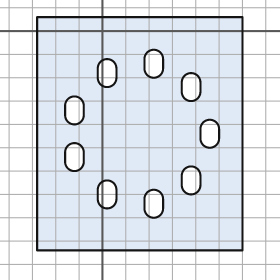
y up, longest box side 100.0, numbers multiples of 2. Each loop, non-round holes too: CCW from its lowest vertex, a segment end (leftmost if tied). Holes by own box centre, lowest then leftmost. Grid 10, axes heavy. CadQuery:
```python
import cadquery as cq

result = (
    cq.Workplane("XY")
    .moveTo(-28.0, -94.0)
    .lineTo(60.0, -94.0)
    .lineTo(60.0, 6.0)
    .lineTo(-28.0, 6.0)
    .close()
    .moveTo(18.0, -76.0)
    .threePointArc((22.0, -80.0), (26.0, -76.0))
    .lineTo(26.0, -72.0)
    .threePointArc((22.0, -68.0), (18.0, -72.0))
    .close()
    .moveTo(-2.0, -72.0)
    .threePointArc((2.0, -76.0), (6.0, -72.0))
    .lineTo(6.0, -68.0)
    .threePointArc((2.0, -64.0), (-2.0, -68.0))
    .close()
    .moveTo(34.0, -66.0)
    .threePointArc((38.0, -70.0), (42.0, -66.0))
    .lineTo(42.0, -62.0)
    .threePointArc((38.0, -58.0), (34.0, -62.0))
    .close()
    .moveTo(-16.0, -56.0)
    .threePointArc((-12.0, -60.0), (-8.0, -56.0))
    .lineTo(-8.0, -52.0)
    .threePointArc((-12.0, -48.0), (-16.0, -52.0))
    .close()
    .moveTo(42.0, -46.0)
    .threePointArc((46.0, -50.0), (50.0, -46.0))
    .lineTo(50.0, -42.0)
    .threePointArc((46.0, -38.0), (42.0, -42.0))
    .close()
    .moveTo(-16.0, -36.0)
    .threePointArc((-12.0, -40.0), (-8.0, -36.0))
    .lineTo(-8.0, -32.0)
    .threePointArc((-12.0, -28.0), (-16.0, -32.0))
    .close()
    .moveTo(34.0, -26.0)
    .threePointArc((38.0, -30.0), (42.0, -26.0))
    .lineTo(42.0, -22.0)
    .threePointArc((38.0, -18.0), (34.0, -22.0))
    .close()
    .moveTo(-2.0, -20.0)
    .threePointArc((2.0, -24.0), (6.0, -20.0))
    .lineTo(6.0, -16.0)
    .threePointArc((2.0, -12.0), (-2.0, -16.0))
    .close()
    .moveTo(18.0, -16.0)
    .threePointArc((22.0, -20.0), (26.0, -16.0))
    .lineTo(26.0, -12.0)
    .threePointArc((22.0, -8.0), (18.0, -12.0))
    .close()
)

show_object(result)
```